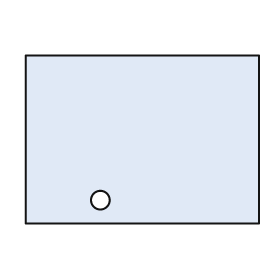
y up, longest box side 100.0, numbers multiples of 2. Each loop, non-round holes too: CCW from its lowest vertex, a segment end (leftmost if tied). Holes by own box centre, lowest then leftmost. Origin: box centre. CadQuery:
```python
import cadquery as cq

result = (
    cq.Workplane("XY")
    .moveTo(-50.0, -36.0)
    .lineTo(50.0, -36.0)
    .lineTo(50.0, 36.0)
    .lineTo(-50.0, 36.0)
    .close()
    .moveTo(-18.0, -26.0)
    .circle(4.0)
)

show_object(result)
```